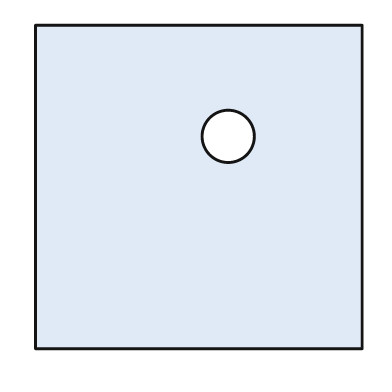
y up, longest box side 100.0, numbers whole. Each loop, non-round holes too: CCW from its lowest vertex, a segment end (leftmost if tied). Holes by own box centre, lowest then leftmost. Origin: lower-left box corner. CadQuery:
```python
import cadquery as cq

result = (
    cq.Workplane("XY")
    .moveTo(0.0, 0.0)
    .lineTo(100.0, 0.0)
    .lineTo(100.0, 99.0)
    .lineTo(0.0, 99.0)
    .close()
    .moveTo(59.0, 65.0)
    .circle(8.0)
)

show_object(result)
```